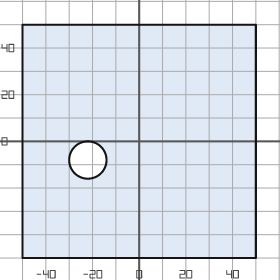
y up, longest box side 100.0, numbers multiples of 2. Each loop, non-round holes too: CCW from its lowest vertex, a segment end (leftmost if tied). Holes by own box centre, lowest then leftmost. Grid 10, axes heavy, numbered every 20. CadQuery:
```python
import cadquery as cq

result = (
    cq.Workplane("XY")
    .moveTo(-50.0, -50.0)
    .lineTo(50.0, -50.0)
    .lineTo(50.0, 50.0)
    .lineTo(-50.0, 50.0)
    .close()
    .moveTo(-22.0, -8.0)
    .circle(8.0)
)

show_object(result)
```